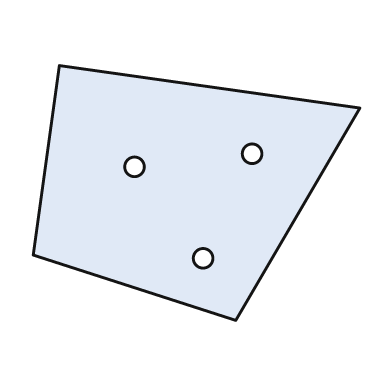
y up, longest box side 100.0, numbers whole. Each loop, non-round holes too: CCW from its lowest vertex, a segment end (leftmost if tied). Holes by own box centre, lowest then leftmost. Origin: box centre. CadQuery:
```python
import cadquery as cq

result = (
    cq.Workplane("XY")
    .moveTo(12.0, -39.0)
    .lineTo(50.0, 26.0)
    .lineTo(-42.0, 39.0)
    .lineTo(-50.0, -19.0)
    .close()
    .moveTo(2.0, -20.0)
    .circle(3.0)
    .moveTo(-19.0, 8.0)
    .circle(3.0)
    .moveTo(17.0, 12.0)
    .circle(3.0)
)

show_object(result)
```